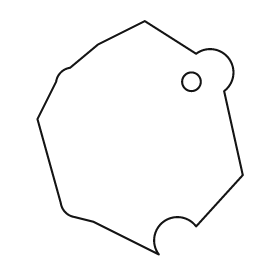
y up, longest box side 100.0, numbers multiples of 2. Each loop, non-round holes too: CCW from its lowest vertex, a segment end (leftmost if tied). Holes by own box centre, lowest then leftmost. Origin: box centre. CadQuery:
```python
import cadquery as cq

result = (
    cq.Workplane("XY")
    .moveTo(8.0, -50.0)
    .threePointArc((10.0, -36.0), (24.0, -38.0))
    .lineTo(44.0, -16.0)
    .lineTo(36.0, 20.0)
    .threePointArc((38.0, 34.0), (24.0, 36.0))
    .lineTo(2.0, 50.0)
    .lineTo(-18.0, 40.0)
    .lineTo(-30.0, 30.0)
    .threePointArc((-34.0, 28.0), (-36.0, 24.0))
    .lineTo(-44.0, 8.0)
    .lineTo(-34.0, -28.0)
    .threePointArc((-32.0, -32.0), (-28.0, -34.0))
    .lineTo(-20.0, -36.0)
    .close()
    .moveTo(22.0, 24.0)
    .circle(4.0)
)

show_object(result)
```